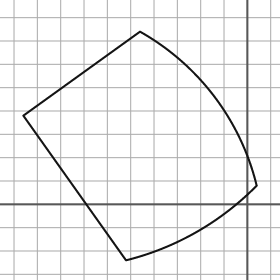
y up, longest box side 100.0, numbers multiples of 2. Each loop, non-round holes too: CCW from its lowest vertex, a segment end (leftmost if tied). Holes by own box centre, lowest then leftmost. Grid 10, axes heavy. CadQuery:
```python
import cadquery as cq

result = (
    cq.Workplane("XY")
    .moveTo(-52.0, -24.0)
    .threePointArc((-22.0, -12.0), (4.0, 8.0))
    .threePointArc((-14.0, 46.0), (-46.0, 74.0))
    .lineTo(-96.0, 38.0)
    .close()
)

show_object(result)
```